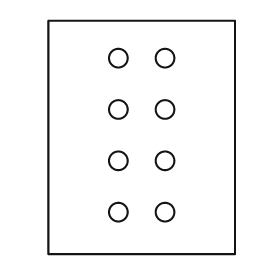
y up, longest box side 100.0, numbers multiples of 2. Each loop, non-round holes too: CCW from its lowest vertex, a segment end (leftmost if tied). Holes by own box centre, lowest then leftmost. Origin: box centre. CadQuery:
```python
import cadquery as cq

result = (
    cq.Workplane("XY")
    .moveTo(-40.0, -50.0)
    .lineTo(40.0, -50.0)
    .lineTo(40.0, 50.0)
    .lineTo(-40.0, 50.0)
    .close()
    .moveTo(-10.0, -32.0)
    .circle(4.0)
    .moveTo(10.0, -32.0)
    .circle(4.0)
    .moveTo(-10.0, -10.0)
    .circle(4.0)
    .moveTo(10.0, -10.0)
    .circle(4.0)
    .moveTo(-10.0, 12.0)
    .circle(4.0)
    .moveTo(10.0, 12.0)
    .circle(4.0)
    .moveTo(-10.0, 34.0)
    .circle(4.0)
    .moveTo(10.0, 34.0)
    .circle(4.0)
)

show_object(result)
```